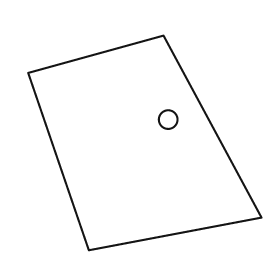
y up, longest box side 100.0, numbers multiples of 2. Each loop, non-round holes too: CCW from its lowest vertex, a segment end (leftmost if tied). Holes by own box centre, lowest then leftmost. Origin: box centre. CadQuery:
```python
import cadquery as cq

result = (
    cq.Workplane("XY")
    .moveTo(-24.0, -46.0)
    .lineTo(50.0, -32.0)
    .lineTo(8.0, 46.0)
    .lineTo(-50.0, 30.0)
    .close()
    .moveTo(10.0, 10.0)
    .circle(4.0)
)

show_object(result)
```